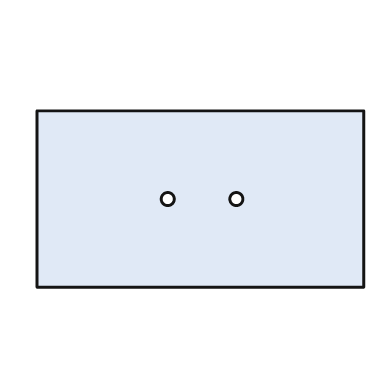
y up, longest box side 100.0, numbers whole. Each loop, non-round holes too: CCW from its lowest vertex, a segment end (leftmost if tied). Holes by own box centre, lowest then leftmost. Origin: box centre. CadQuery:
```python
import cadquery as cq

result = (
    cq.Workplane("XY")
    .moveTo(-50.0, -27.0)
    .lineTo(50.0, -27.0)
    .lineTo(50.0, 27.0)
    .lineTo(-50.0, 27.0)
    .close()
    .moveTo(-10.0, 0.0)
    .circle(2.0)
    .moveTo(11.0, 0.0)
    .circle(2.0)
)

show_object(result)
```